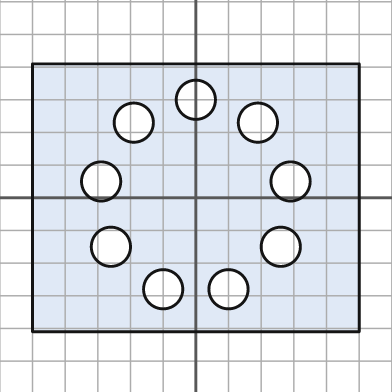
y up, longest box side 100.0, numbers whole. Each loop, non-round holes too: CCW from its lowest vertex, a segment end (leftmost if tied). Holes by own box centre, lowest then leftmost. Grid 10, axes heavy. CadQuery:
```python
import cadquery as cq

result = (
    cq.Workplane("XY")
    .moveTo(-50.0, -41.0)
    .lineTo(50.0, -41.0)
    .lineTo(50.0, 41.0)
    .lineTo(-50.0, 41.0)
    .close()
    .moveTo(-10.0, -28.0)
    .circle(6.0)
    .moveTo(10.0, -28.0)
    .circle(6.0)
    .moveTo(-26.0, -15.0)
    .circle(6.0)
    .moveTo(26.0, -15.0)
    .circle(6.0)
    .moveTo(-29.0, 5.0)
    .circle(6.0)
    .moveTo(29.0, 5.0)
    .circle(6.0)
    .moveTo(-19.0, 23.0)
    .circle(6.0)
    .moveTo(19.0, 23.0)
    .circle(6.0)
    .moveTo(0.0, 30.0)
    .circle(6.0)
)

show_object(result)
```